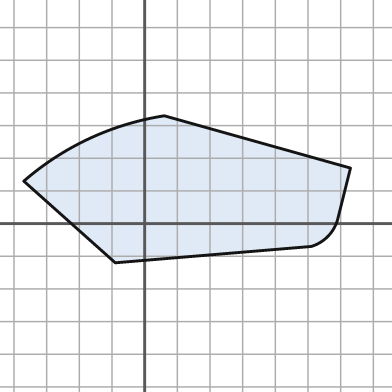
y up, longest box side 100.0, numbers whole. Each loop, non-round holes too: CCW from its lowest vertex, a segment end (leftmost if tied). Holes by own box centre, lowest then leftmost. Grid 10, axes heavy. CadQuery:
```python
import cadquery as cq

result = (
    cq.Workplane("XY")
    .moveTo(-9.0, -12.0)
    .lineTo(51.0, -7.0)
    .threePointArc((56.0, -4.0), (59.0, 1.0))
    .lineTo(63.0, 17.0)
    .lineTo(6.0, 33.0)
    .threePointArc((-17.0, 26.0), (-37.0, 13.0))
    .close()
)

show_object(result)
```